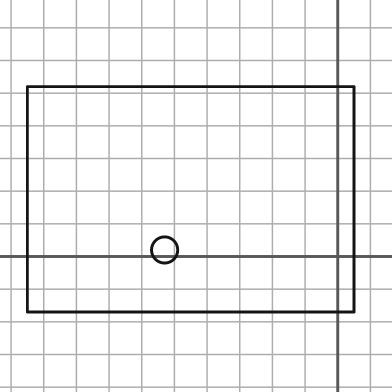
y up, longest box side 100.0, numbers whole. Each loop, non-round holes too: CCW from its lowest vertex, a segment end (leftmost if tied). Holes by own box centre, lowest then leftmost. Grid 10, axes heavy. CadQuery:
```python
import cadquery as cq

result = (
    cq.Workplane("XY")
    .moveTo(-95.0, -17.0)
    .lineTo(5.0, -17.0)
    .lineTo(5.0, 52.0)
    .lineTo(-95.0, 52.0)
    .close()
    .moveTo(-53.0, 2.0)
    .circle(4.0)
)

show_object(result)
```